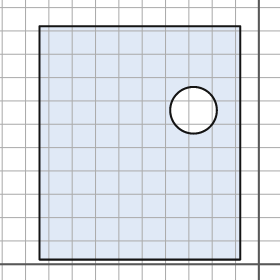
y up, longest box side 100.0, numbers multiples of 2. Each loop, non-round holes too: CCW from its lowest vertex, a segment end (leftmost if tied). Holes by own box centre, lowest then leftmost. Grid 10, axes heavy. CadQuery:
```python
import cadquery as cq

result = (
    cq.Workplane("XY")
    .moveTo(-94.0, 2.0)
    .lineTo(-8.0, 2.0)
    .lineTo(-8.0, 102.0)
    .lineTo(-94.0, 102.0)
    .close()
    .moveTo(-28.0, 66.0)
    .circle(10.0)
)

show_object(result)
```